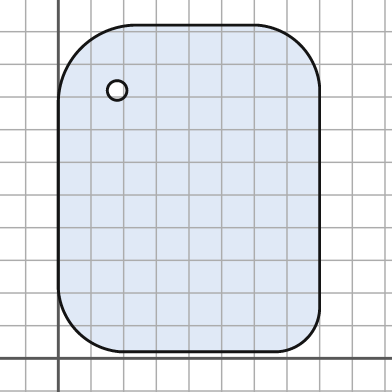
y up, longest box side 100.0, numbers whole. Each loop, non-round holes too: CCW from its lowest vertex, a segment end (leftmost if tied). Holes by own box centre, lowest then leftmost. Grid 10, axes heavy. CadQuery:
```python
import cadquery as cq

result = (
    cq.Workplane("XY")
    .moveTo(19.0, 2.0)
    .lineTo(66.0, 2.0)
    .threePointArc((76.0, 6.0), (80.0, 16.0))
    .lineTo(80.0, 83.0)
    .threePointArc((74.0, 96.0), (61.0, 102.0))
    .lineTo(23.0, 102.0)
    .threePointArc((7.0, 95.0), (0.0, 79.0))
    .lineTo(0.0, 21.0)
    .threePointArc((6.0, 8.0), (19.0, 2.0))
    .close()
    .moveTo(18.0, 82.0)
    .circle(3.0)
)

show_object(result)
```